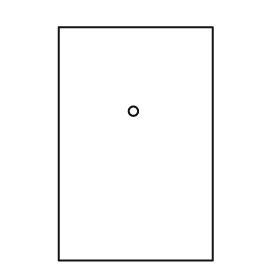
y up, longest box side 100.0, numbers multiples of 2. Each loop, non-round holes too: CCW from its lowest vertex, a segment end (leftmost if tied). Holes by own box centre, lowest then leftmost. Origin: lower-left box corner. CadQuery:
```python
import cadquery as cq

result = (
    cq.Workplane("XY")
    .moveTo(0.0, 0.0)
    .lineTo(66.0, 0.0)
    .lineTo(66.0, 100.0)
    .lineTo(0.0, 100.0)
    .close()
    .moveTo(32.0, 64.0)
    .circle(2.0)
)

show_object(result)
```